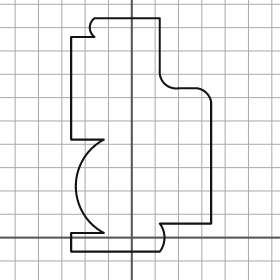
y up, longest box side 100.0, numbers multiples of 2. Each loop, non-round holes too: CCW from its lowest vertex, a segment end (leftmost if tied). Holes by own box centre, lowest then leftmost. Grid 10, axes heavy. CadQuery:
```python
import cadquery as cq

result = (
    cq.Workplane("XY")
    .moveTo(-26.0, -6.0)
    .lineTo(12.0, -6.0)
    .threePointArc((14.0, 0.0), (12.0, 6.0))
    .lineTo(34.0, 6.0)
    .lineTo(34.0, 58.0)
    .threePointArc((32.0, 62.0), (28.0, 64.0))
    .lineTo(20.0, 64.0)
    .threePointArc((14.0, 66.0), (12.0, 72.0))
    .lineTo(12.0, 94.0)
    .lineTo(-16.0, 94.0)
    .threePointArc((-18.0, 90.0), (-16.0, 86.0))
    .lineTo(-26.0, 86.0)
    .lineTo(-26.0, 42.0)
    .lineTo(-12.0, 42.0)
    .threePointArc((-24.0, 22.0), (-12.0, 2.0))
    .lineTo(-26.0, 2.0)
    .close()
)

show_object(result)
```